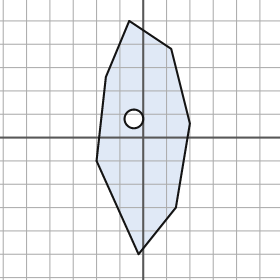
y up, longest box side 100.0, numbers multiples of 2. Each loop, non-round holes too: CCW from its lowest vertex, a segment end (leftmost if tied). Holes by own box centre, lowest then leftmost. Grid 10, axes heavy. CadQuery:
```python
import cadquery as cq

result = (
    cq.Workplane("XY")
    .moveTo(-2.0, -50.0)
    .lineTo(14.0, -30.0)
    .lineTo(20.0, 6.0)
    .lineTo(12.0, 38.0)
    .lineTo(-6.0, 50.0)
    .lineTo(-16.0, 26.0)
    .lineTo(-20.0, -10.0)
    .close()
    .moveTo(-4.0, 8.0)
    .circle(4.0)
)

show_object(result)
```